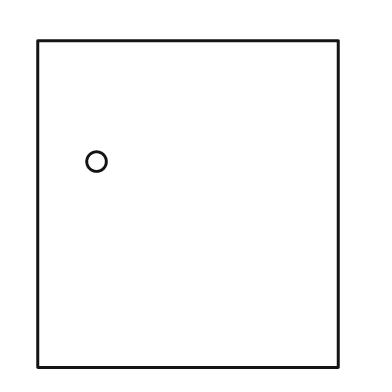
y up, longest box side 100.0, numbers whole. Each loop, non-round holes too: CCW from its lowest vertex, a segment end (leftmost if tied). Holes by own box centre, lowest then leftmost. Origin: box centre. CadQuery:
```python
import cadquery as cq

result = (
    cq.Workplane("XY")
    .moveTo(-46.0, -50.0)
    .lineTo(46.0, -50.0)
    .lineTo(46.0, 50.0)
    .lineTo(-46.0, 50.0)
    .close()
    .moveTo(-28.0, 13.0)
    .circle(3.0)
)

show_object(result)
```